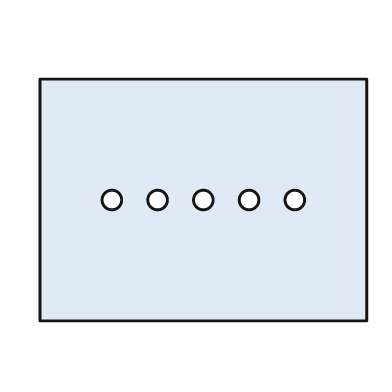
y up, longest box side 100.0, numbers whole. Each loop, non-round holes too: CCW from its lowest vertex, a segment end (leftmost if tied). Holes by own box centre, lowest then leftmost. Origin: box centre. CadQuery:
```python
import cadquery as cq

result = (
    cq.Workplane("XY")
    .moveTo(-50.0, -37.0)
    .lineTo(50.0, -37.0)
    .lineTo(50.0, 37.0)
    .lineTo(-50.0, 37.0)
    .close()
    .moveTo(-28.0, 0.0)
    .circle(3.0)
    .moveTo(-14.0, 0.0)
    .circle(3.0)
    .moveTo(0.0, 0.0)
    .circle(3.0)
    .moveTo(14.0, 0.0)
    .circle(3.0)
    .moveTo(28.0, 0.0)
    .circle(3.0)
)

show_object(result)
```